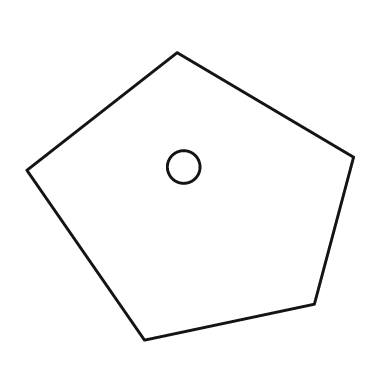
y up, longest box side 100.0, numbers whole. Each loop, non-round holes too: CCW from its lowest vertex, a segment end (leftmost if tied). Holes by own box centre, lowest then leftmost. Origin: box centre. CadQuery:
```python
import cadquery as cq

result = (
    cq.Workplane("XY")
    .moveTo(-14.0, -44.0)
    .lineTo(38.0, -33.0)
    .lineTo(50.0, 12.0)
    .lineTo(-4.0, 44.0)
    .lineTo(-50.0, 8.0)
    .close()
    .moveTo(-2.0, 9.0)
    .circle(5.0)
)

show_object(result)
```